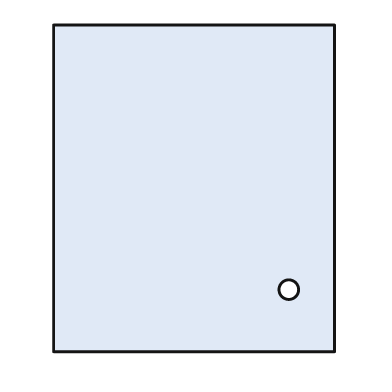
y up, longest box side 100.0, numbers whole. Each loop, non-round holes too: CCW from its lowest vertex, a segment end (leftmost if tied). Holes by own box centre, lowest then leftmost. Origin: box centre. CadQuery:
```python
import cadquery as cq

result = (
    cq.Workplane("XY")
    .moveTo(-43.0, -50.0)
    .lineTo(43.0, -50.0)
    .lineTo(43.0, 50.0)
    .lineTo(-43.0, 50.0)
    .close()
    .moveTo(29.0, -31.0)
    .circle(3.0)
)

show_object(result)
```